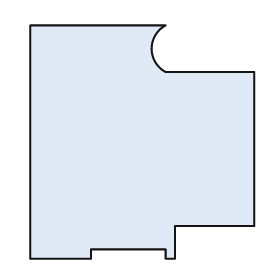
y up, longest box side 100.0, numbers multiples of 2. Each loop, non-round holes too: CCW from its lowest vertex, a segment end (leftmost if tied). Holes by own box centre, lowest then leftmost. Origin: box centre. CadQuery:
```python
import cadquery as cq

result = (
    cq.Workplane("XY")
    .moveTo(-48.0, -50.0)
    .lineTo(-22.0, -50.0)
    .lineTo(-22.0, -46.0)
    .lineTo(10.0, -46.0)
    .lineTo(10.0, -50.0)
    .lineTo(14.0, -50.0)
    .lineTo(14.0, -36.0)
    .lineTo(48.0, -36.0)
    .lineTo(48.0, 30.0)
    .lineTo(10.0, 30.0)
    .threePointArc((4.0, 40.0), (10.0, 50.0))
    .lineTo(-48.0, 50.0)
    .close()
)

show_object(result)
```